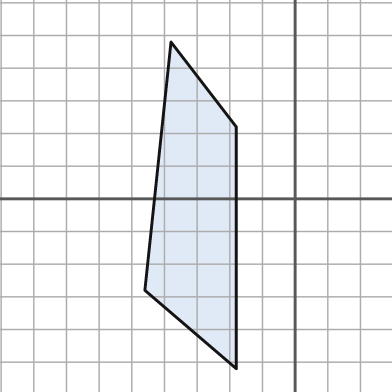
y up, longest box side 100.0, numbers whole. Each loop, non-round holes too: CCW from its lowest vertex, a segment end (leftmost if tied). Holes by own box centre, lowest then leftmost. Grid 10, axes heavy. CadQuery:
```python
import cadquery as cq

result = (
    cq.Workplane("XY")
    .moveTo(-18.0, -52.0)
    .lineTo(-18.0, 22.0)
    .lineTo(-38.0, 48.0)
    .lineTo(-46.0, -28.0)
    .close()
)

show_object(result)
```